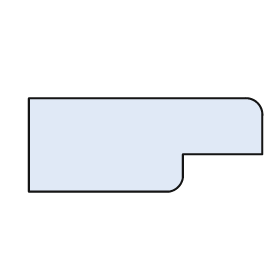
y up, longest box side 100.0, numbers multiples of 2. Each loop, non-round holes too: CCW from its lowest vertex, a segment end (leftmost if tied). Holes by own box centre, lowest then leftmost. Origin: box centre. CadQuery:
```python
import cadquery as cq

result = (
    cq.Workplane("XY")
    .moveTo(-50.0, -20.0)
    .lineTo(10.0, -20.0)
    .threePointArc((14.0, -18.0), (16.0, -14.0))
    .lineTo(16.0, -4.0)
    .lineTo(50.0, -4.0)
    .lineTo(50.0, 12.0)
    .threePointArc((48.0, 18.0), (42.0, 20.0))
    .lineTo(-50.0, 20.0)
    .close()
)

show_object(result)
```